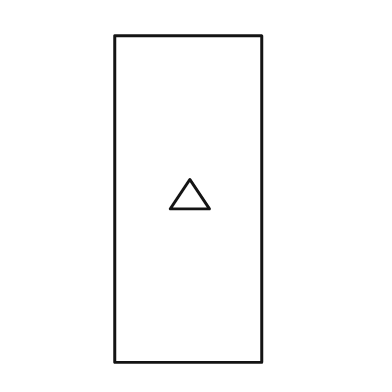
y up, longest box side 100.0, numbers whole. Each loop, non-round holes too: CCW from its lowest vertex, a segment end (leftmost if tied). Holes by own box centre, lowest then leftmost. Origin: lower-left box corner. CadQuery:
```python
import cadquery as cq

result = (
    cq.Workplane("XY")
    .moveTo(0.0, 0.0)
    .lineTo(45.0, 0.0)
    .lineTo(45.0, 100.0)
    .lineTo(0.0, 100.0)
    .close()
    .moveTo(17.0, 47.0)
    .lineTo(29.0, 47.0)
    .lineTo(23.0, 56.0)
    .close()
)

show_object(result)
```